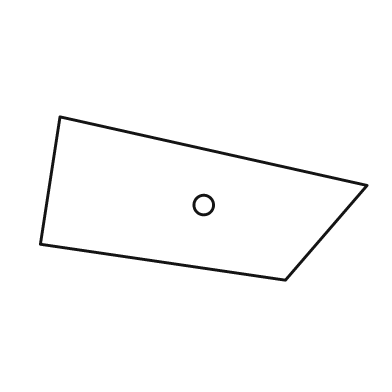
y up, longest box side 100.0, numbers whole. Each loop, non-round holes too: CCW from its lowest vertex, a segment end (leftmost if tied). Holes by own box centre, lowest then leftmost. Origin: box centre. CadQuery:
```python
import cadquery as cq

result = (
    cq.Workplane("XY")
    .moveTo(25.0, -25.0)
    .lineTo(50.0, 4.0)
    .lineTo(-44.0, 25.0)
    .lineTo(-50.0, -14.0)
    .close()
    .moveTo(0.0, -2.0)
    .circle(3.0)
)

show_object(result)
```